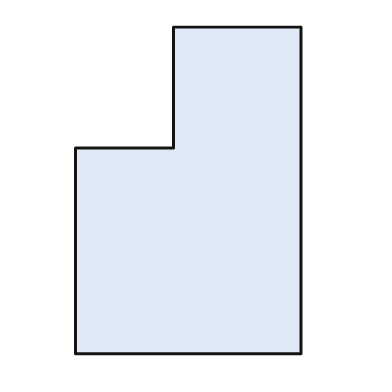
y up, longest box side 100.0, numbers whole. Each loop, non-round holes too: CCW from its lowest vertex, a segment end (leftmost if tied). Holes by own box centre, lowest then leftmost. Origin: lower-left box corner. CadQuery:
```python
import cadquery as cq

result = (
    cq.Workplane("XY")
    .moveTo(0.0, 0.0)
    .lineTo(69.0, 0.0)
    .lineTo(69.0, 100.0)
    .lineTo(30.0, 100.0)
    .lineTo(30.0, 63.0)
    .lineTo(0.0, 63.0)
    .close()
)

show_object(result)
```